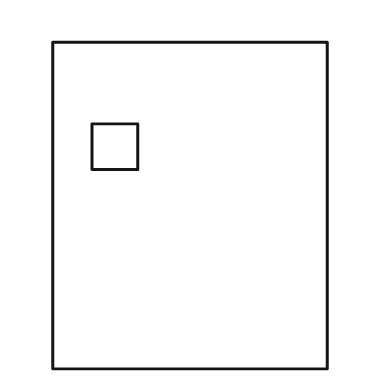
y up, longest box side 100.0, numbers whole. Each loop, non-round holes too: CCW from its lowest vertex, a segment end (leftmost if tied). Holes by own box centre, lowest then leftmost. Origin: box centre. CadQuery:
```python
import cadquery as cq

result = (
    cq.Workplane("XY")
    .moveTo(-42.0, -50.0)
    .lineTo(42.0, -50.0)
    .lineTo(42.0, 50.0)
    .lineTo(-42.0, 50.0)
    .close()
    .moveTo(-30.0, 11.0)
    .lineTo(-16.0, 11.0)
    .lineTo(-16.0, 25.0)
    .lineTo(-30.0, 25.0)
    .close()
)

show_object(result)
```